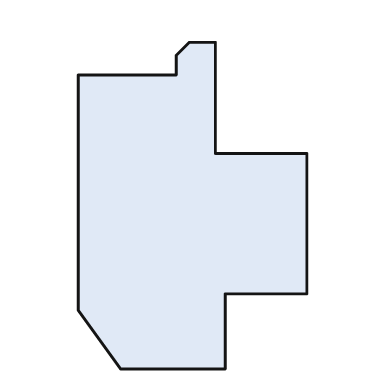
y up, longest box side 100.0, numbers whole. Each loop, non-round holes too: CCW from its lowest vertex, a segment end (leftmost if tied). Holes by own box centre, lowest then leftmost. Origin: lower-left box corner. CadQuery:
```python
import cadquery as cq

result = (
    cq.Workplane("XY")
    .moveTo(13.0, 0.0)
    .lineTo(45.0, 0.0)
    .lineTo(45.0, 23.0)
    .lineTo(70.0, 23.0)
    .lineTo(70.0, 66.0)
    .lineTo(42.0, 66.0)
    .lineTo(42.0, 100.0)
    .lineTo(34.0, 100.0)
    .lineTo(30.0, 96.0)
    .lineTo(30.0, 90.0)
    .lineTo(0.0, 90.0)
    .lineTo(0.0, 18.0)
    .close()
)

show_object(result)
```